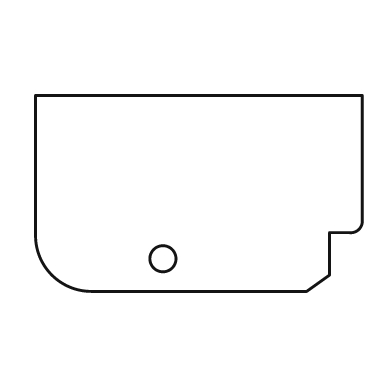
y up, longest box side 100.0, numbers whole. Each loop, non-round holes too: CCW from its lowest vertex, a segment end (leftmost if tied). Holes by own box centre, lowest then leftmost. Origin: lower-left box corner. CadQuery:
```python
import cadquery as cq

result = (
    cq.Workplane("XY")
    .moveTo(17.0, 0.0)
    .lineTo(83.0, 0.0)
    .lineTo(90.0, 5.0)
    .lineTo(90.0, 18.0)
    .lineTo(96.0, 18.0)
    .threePointArc((99.0, 19.0), (100.0, 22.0))
    .lineTo(100.0, 60.0)
    .lineTo(0.0, 60.0)
    .lineTo(0.0, 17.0)
    .threePointArc((5.0, 5.0), (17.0, 0.0))
    .close()
    .moveTo(39.0, 10.0)
    .circle(4.0)
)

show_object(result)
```